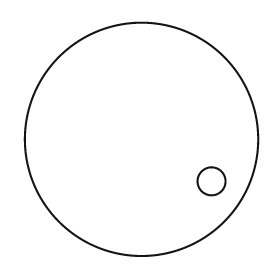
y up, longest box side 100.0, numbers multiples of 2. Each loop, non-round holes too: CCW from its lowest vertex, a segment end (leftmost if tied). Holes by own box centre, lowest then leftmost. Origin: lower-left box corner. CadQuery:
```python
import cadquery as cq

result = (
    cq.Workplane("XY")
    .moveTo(50.0, 50.0)
    .circle(50.0)
    .moveTo(80.0, 32.0)
    .circle(6.0)
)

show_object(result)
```